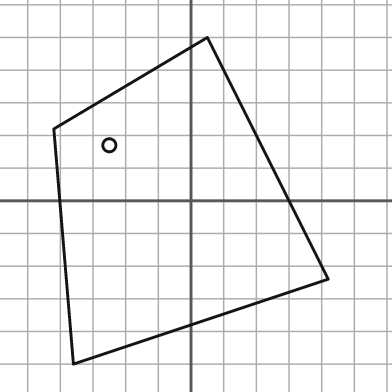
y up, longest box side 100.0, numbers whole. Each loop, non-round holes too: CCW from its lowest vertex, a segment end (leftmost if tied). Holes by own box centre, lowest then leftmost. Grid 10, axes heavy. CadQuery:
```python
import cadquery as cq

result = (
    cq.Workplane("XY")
    .moveTo(-36.0, -50.0)
    .lineTo(42.0, -24.0)
    .lineTo(5.0, 50.0)
    .lineTo(-42.0, 22.0)
    .close()
    .moveTo(-25.0, 17.0)
    .circle(2.0)
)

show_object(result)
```